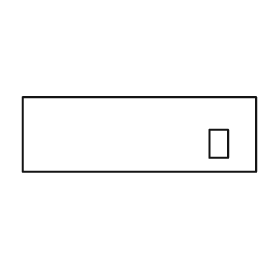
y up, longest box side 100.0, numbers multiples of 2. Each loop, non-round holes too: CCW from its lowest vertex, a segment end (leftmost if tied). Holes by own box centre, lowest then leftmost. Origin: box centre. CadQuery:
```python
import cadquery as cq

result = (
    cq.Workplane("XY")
    .moveTo(-50.0, -16.0)
    .lineTo(50.0, -16.0)
    .lineTo(50.0, 16.0)
    .lineTo(-50.0, 16.0)
    .close()
    .moveTo(30.0, -10.0)
    .lineTo(38.0, -10.0)
    .lineTo(38.0, 2.0)
    .lineTo(30.0, 2.0)
    .close()
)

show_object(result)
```